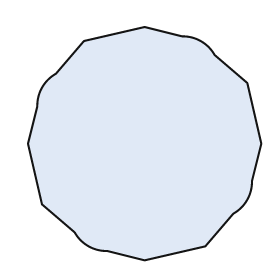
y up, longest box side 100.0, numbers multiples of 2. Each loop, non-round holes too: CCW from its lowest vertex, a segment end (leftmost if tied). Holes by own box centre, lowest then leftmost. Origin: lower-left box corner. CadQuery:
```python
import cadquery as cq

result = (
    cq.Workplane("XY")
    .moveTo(50.0, 0.0)
    .lineTo(76.0, 6.0)
    .lineTo(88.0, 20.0)
    .threePointArc((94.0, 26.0), (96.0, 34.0))
    .lineTo(100.0, 50.0)
    .lineTo(94.0, 76.0)
    .lineTo(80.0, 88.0)
    .threePointArc((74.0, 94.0), (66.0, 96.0))
    .lineTo(50.0, 100.0)
    .lineTo(24.0, 94.0)
    .lineTo(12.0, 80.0)
    .threePointArc((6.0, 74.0), (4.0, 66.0))
    .lineTo(0.0, 50.0)
    .lineTo(6.0, 24.0)
    .lineTo(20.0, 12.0)
    .threePointArc((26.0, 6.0), (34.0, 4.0))
    .close()
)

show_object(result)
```